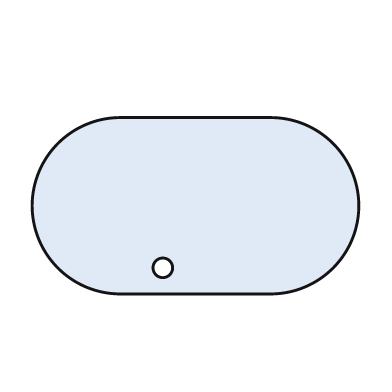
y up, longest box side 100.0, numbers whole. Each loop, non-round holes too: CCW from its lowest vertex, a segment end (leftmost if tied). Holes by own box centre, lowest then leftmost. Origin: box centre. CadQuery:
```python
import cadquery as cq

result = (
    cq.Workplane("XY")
    .moveTo(-23.0, -27.0)
    .lineTo(23.0, -27.0)
    .threePointArc((50.0, 0.0), (23.0, 27.0))
    .lineTo(-23.0, 27.0)
    .threePointArc((-50.0, 0.0), (-23.0, -27.0))
    .close()
    .moveTo(-10.0, -19.0)
    .circle(3.0)
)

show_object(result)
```